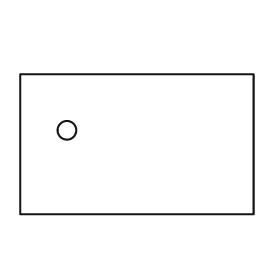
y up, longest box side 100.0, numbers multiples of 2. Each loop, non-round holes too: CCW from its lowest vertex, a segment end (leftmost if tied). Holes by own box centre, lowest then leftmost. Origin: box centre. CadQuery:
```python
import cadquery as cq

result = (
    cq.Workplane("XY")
    .moveTo(-50.0, -30.0)
    .lineTo(50.0, -30.0)
    .lineTo(50.0, 30.0)
    .lineTo(-50.0, 30.0)
    .close()
    .moveTo(-30.0, 6.0)
    .circle(4.0)
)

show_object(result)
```